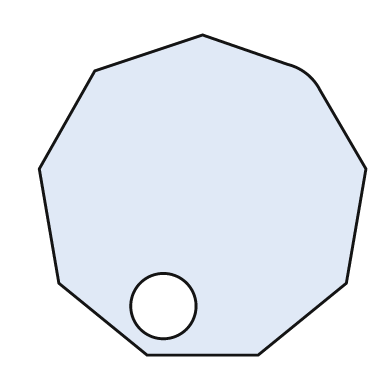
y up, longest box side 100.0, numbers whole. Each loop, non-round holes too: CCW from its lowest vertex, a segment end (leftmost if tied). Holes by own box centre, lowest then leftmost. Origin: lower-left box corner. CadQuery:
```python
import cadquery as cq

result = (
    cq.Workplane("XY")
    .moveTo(33.0, 0.0)
    .lineTo(67.0, 0.0)
    .lineTo(94.0, 22.0)
    .lineTo(100.0, 57.0)
    .lineTo(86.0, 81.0)
    .threePointArc((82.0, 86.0), (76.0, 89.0))
    .lineTo(50.0, 98.0)
    .lineTo(17.0, 87.0)
    .lineTo(0.0, 57.0)
    .lineTo(6.0, 22.0)
    .close()
    .moveTo(38.0, 15.0)
    .circle(10.0)
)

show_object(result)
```